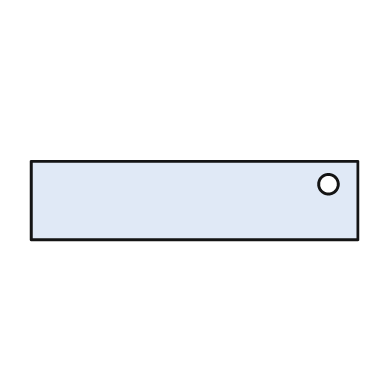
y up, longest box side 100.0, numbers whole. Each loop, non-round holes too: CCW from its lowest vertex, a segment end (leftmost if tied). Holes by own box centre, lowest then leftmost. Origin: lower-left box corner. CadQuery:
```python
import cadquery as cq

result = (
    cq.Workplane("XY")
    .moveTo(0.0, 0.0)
    .lineTo(100.0, 0.0)
    .lineTo(100.0, 24.0)
    .lineTo(0.0, 24.0)
    .close()
    .moveTo(91.0, 17.0)
    .circle(3.0)
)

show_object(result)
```